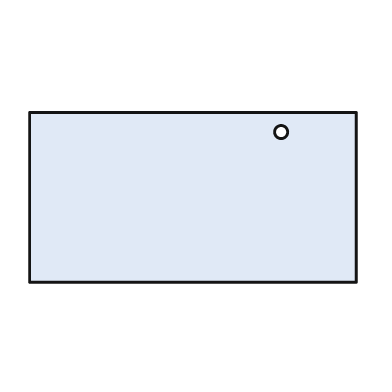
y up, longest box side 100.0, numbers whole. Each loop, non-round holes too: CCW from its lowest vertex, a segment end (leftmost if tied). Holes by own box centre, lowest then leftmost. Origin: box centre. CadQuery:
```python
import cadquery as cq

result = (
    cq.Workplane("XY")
    .moveTo(-50.0, -26.0)
    .lineTo(50.0, -26.0)
    .lineTo(50.0, 26.0)
    .lineTo(-50.0, 26.0)
    .close()
    .moveTo(27.0, 20.0)
    .circle(2.0)
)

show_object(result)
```